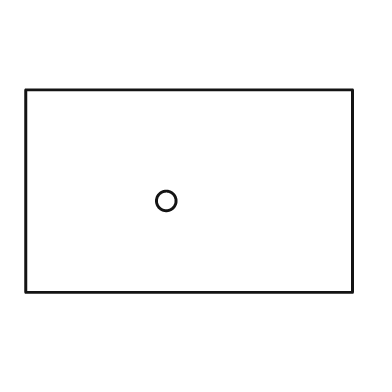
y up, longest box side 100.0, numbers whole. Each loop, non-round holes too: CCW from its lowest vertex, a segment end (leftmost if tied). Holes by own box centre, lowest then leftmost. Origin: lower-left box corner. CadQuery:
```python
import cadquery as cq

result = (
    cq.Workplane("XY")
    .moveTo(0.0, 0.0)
    .lineTo(100.0, 0.0)
    .lineTo(100.0, 62.0)
    .lineTo(0.0, 62.0)
    .close()
    .moveTo(43.0, 28.0)
    .circle(3.0)
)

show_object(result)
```